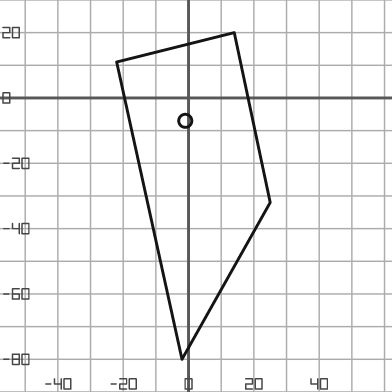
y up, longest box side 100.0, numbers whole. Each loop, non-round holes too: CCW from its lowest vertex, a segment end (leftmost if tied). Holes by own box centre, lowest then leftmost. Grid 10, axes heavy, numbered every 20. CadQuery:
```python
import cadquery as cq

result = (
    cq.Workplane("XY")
    .moveTo(-2.0, -80.0)
    .lineTo(25.0, -32.0)
    .lineTo(14.0, 20.0)
    .lineTo(-22.0, 11.0)
    .close()
    .moveTo(-1.0, -7.0)
    .circle(2.0)
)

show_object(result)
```